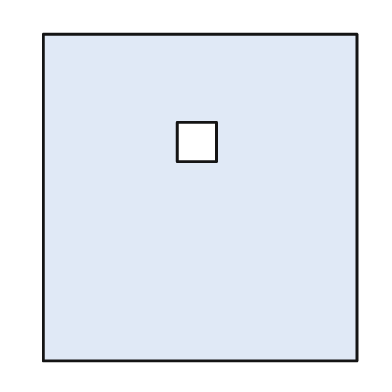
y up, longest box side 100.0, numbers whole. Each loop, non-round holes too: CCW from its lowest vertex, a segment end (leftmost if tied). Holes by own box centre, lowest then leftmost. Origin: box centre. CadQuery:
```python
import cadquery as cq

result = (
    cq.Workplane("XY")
    .moveTo(-48.0, -50.0)
    .lineTo(48.0, -50.0)
    .lineTo(48.0, 50.0)
    .lineTo(-48.0, 50.0)
    .close()
    .moveTo(-7.0, 11.0)
    .lineTo(5.0, 11.0)
    .lineTo(5.0, 23.0)
    .lineTo(-7.0, 23.0)
    .close()
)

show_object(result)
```